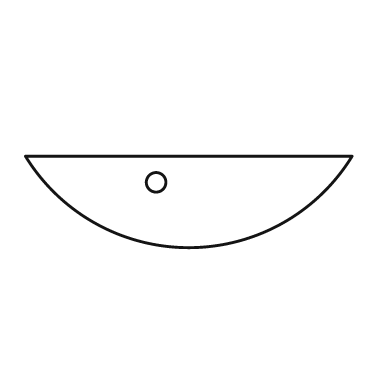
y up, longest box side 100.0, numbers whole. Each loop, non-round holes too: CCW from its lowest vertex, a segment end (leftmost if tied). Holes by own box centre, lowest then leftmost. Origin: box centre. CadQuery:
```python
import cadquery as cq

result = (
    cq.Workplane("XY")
    .moveTo(-50.0, 14.0)
    .threePointArc((0.0, -14.0), (50.0, 14.0))
    .close()
    .moveTo(-10.0, 6.0)
    .circle(3.0)
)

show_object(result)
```